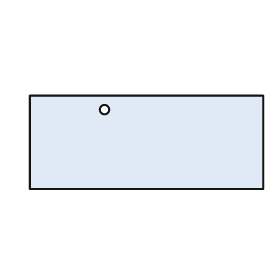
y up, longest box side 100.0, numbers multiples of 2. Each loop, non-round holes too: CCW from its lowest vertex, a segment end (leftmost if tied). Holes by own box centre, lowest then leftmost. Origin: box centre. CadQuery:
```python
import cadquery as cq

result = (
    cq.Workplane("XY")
    .moveTo(-50.0, -20.0)
    .lineTo(50.0, -20.0)
    .lineTo(50.0, 20.0)
    .lineTo(-50.0, 20.0)
    .close()
    .moveTo(-18.0, 14.0)
    .circle(2.0)
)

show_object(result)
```